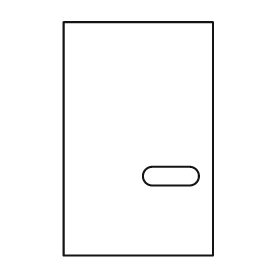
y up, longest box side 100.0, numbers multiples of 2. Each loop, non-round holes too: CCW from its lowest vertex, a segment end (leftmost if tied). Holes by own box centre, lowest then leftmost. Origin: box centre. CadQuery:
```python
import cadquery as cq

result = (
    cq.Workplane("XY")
    .moveTo(-32.0, -50.0)
    .lineTo(32.0, -50.0)
    .lineTo(32.0, 50.0)
    .lineTo(-32.0, 50.0)
    .close()
    .moveTo(6.0, -20.0)
    .lineTo(22.0, -20.0)
    .threePointArc((26.0, -16.0), (22.0, -12.0))
    .lineTo(6.0, -12.0)
    .threePointArc((2.0, -16.0), (6.0, -20.0))
    .close()
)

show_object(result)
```